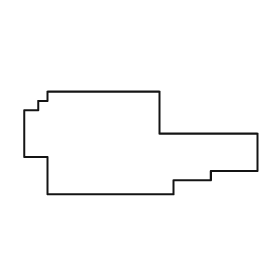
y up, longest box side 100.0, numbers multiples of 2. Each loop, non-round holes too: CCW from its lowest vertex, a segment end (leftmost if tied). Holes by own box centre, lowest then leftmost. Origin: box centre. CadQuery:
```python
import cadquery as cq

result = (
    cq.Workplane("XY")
    .moveTo(-40.0, -22.0)
    .lineTo(14.0, -22.0)
    .lineTo(14.0, -16.0)
    .lineTo(30.0, -16.0)
    .lineTo(30.0, -12.0)
    .lineTo(50.0, -12.0)
    .lineTo(50.0, 4.0)
    .lineTo(8.0, 4.0)
    .lineTo(8.0, 22.0)
    .lineTo(-40.0, 22.0)
    .lineTo(-40.0, 18.0)
    .lineTo(-44.0, 18.0)
    .lineTo(-44.0, 14.0)
    .lineTo(-50.0, 14.0)
    .lineTo(-50.0, -6.0)
    .lineTo(-40.0, -6.0)
    .close()
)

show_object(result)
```